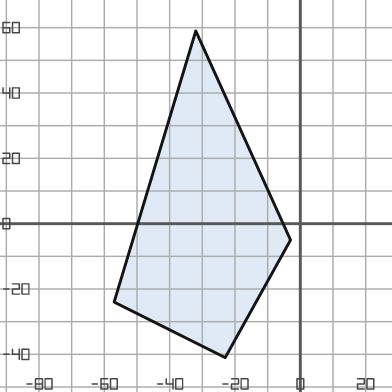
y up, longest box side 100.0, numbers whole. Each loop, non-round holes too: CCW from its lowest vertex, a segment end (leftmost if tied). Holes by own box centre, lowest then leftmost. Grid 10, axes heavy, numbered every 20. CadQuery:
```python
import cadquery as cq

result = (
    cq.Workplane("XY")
    .moveTo(-23.0, -41.0)
    .lineTo(-3.0, -5.0)
    .lineTo(-32.0, 59.0)
    .lineTo(-57.0, -24.0)
    .close()
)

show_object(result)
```